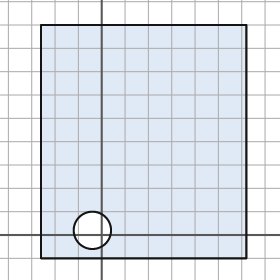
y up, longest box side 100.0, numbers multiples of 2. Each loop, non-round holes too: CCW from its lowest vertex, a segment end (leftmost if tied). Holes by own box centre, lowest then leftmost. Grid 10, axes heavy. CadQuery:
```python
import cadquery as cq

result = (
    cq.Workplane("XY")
    .moveTo(-26.0, -10.0)
    .lineTo(62.0, -10.0)
    .lineTo(62.0, 90.0)
    .lineTo(-26.0, 90.0)
    .close()
    .moveTo(-4.0, 2.0)
    .circle(8.0)
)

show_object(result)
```